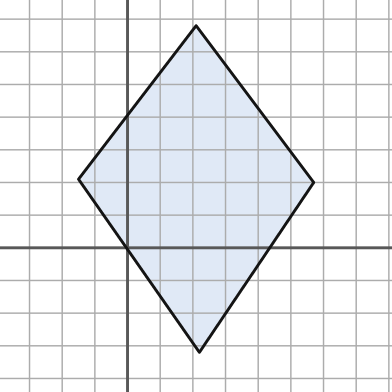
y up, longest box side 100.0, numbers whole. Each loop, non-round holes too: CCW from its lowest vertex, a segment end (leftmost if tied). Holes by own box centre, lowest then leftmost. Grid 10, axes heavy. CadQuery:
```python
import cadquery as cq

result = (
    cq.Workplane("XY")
    .moveTo(22.0, -32.0)
    .lineTo(57.0, 20.0)
    .lineTo(21.0, 68.0)
    .lineTo(-15.0, 21.0)
    .close()
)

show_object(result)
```